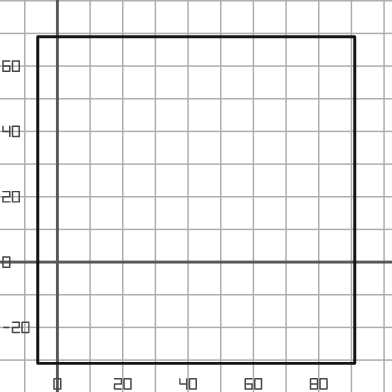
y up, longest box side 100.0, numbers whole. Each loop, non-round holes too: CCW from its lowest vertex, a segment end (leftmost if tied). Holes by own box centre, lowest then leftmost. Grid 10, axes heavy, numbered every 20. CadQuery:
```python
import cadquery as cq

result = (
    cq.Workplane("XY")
    .moveTo(-6.0, -31.0)
    .lineTo(91.0, -31.0)
    .lineTo(91.0, 69.0)
    .lineTo(-6.0, 69.0)
    .close()
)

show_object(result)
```